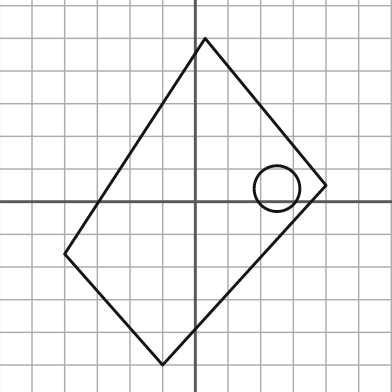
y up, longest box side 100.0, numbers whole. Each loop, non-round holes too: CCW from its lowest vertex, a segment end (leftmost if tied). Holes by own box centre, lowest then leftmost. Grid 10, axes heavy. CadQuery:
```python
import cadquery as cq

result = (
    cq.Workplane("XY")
    .moveTo(-10.0, -50.0)
    .lineTo(40.0, 5.0)
    .lineTo(3.0, 50.0)
    .lineTo(-40.0, -16.0)
    .close()
    .moveTo(25.0, 4.0)
    .circle(7.0)
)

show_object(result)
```